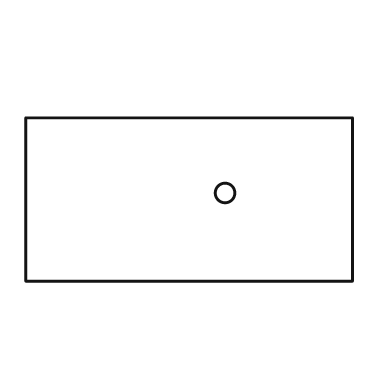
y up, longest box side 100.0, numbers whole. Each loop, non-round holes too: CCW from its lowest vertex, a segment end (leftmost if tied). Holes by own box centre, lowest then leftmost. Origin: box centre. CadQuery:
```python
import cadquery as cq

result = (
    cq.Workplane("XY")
    .moveTo(-50.0, -25.0)
    .lineTo(50.0, -25.0)
    .lineTo(50.0, 25.0)
    .lineTo(-50.0, 25.0)
    .close()
    .moveTo(11.0, 2.0)
    .circle(3.0)
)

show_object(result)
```